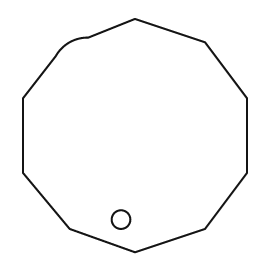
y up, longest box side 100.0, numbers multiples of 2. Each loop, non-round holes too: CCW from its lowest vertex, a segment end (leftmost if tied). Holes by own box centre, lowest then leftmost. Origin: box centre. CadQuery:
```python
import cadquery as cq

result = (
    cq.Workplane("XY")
    .moveTo(0.0, -50.0)
    .lineTo(30.0, -40.0)
    .lineTo(48.0, -16.0)
    .lineTo(48.0, 16.0)
    .lineTo(30.0, 40.0)
    .lineTo(0.0, 50.0)
    .lineTo(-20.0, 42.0)
    .threePointArc((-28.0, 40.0), (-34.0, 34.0))
    .lineTo(-48.0, 16.0)
    .lineTo(-48.0, -16.0)
    .lineTo(-28.0, -40.0)
    .close()
    .moveTo(-6.0, -36.0)
    .circle(4.0)
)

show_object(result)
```